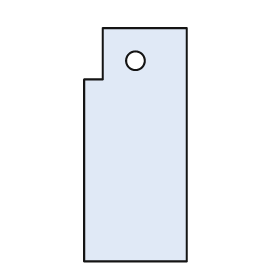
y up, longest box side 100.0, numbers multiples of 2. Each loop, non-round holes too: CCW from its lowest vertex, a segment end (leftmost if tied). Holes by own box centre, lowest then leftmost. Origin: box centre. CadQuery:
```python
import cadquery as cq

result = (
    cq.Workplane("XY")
    .moveTo(-22.0, -50.0)
    .lineTo(22.0, -50.0)
    .lineTo(22.0, 50.0)
    .lineTo(-14.0, 50.0)
    .lineTo(-14.0, 28.0)
    .lineTo(-22.0, 28.0)
    .close()
    .moveTo(0.0, 36.0)
    .circle(4.0)
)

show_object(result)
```